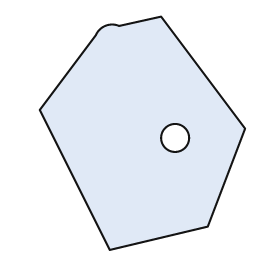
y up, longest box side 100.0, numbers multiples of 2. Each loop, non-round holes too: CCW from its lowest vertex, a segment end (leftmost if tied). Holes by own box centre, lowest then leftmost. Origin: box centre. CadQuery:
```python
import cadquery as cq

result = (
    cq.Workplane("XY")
    .moveTo(-14.0, -50.0)
    .lineTo(28.0, -40.0)
    .lineTo(44.0, 2.0)
    .lineTo(8.0, 50.0)
    .lineTo(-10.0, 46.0)
    .threePointArc((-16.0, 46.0), (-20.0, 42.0))
    .lineTo(-44.0, 10.0)
    .close()
    .moveTo(14.0, -2.0)
    .circle(6.0)
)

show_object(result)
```